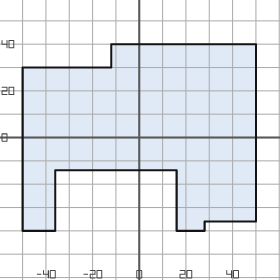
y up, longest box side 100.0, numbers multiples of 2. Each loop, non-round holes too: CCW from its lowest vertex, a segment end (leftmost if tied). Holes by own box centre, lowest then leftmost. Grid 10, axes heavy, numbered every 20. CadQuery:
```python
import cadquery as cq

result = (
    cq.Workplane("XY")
    .moveTo(-50.0, -40.0)
    .lineTo(-36.0, -40.0)
    .lineTo(-36.0, -14.0)
    .lineTo(16.0, -14.0)
    .lineTo(16.0, -40.0)
    .lineTo(28.0, -40.0)
    .lineTo(28.0, -36.0)
    .lineTo(50.0, -36.0)
    .lineTo(50.0, 40.0)
    .lineTo(-12.0, 40.0)
    .lineTo(-12.0, 30.0)
    .lineTo(-50.0, 30.0)
    .close()
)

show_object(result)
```